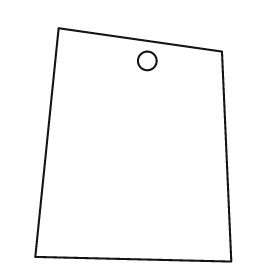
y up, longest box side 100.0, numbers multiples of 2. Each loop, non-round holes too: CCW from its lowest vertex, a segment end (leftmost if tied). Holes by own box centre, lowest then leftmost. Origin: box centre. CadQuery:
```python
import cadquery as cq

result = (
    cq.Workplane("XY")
    .moveTo(42.0, -50.0)
    .lineTo(38.0, 40.0)
    .lineTo(-32.0, 50.0)
    .lineTo(-42.0, -48.0)
    .close()
    .moveTo(6.0, 36.0)
    .circle(4.0)
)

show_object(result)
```